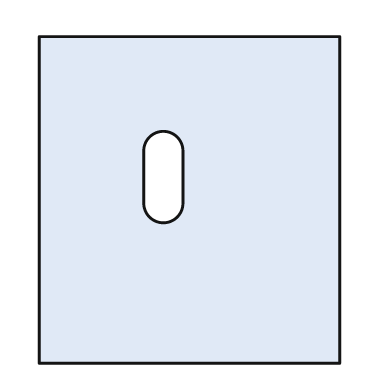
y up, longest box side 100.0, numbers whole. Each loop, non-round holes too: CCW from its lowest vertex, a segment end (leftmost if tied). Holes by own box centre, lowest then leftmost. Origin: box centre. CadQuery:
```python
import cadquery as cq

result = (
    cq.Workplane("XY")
    .moveTo(-46.0, -50.0)
    .lineTo(46.0, -50.0)
    .lineTo(46.0, 50.0)
    .lineTo(-46.0, 50.0)
    .close()
    .moveTo(-14.0, -1.0)
    .threePointArc((-8.0, -7.0), (-2.0, -1.0))
    .lineTo(-2.0, 15.0)
    .threePointArc((-8.0, 21.0), (-14.0, 15.0))
    .close()
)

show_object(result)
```